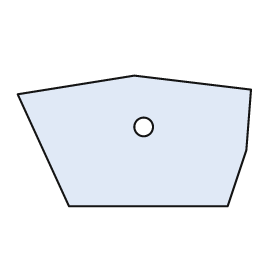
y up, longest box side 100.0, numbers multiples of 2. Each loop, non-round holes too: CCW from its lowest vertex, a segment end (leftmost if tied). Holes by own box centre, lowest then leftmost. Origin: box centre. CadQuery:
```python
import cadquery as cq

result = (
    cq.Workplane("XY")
    .moveTo(-28.0, -28.0)
    .lineTo(40.0, -28.0)
    .lineTo(48.0, -4.0)
    .lineTo(50.0, 22.0)
    .lineTo(0.0, 28.0)
    .lineTo(-50.0, 20.0)
    .close()
    .moveTo(4.0, 6.0)
    .circle(4.0)
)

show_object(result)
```